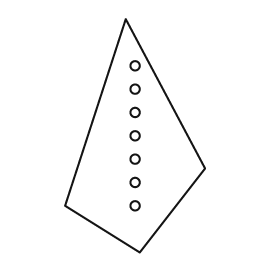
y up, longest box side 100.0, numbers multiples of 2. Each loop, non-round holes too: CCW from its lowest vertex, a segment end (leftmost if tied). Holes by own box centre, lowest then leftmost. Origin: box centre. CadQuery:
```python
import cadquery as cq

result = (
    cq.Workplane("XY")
    .moveTo(2.0, -50.0)
    .lineTo(30.0, -14.0)
    .lineTo(-4.0, 50.0)
    .lineTo(-30.0, -30.0)
    .close()
    .moveTo(0.0, -30.0)
    .circle(2.0)
    .moveTo(0.0, -20.0)
    .circle(2.0)
    .moveTo(0.0, -10.0)
    .circle(2.0)
    .moveTo(0.0, 0.0)
    .circle(2.0)
    .moveTo(0.0, 10.0)
    .circle(2.0)
    .moveTo(0.0, 20.0)
    .circle(2.0)
    .moveTo(0.0, 30.0)
    .circle(2.0)
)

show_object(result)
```